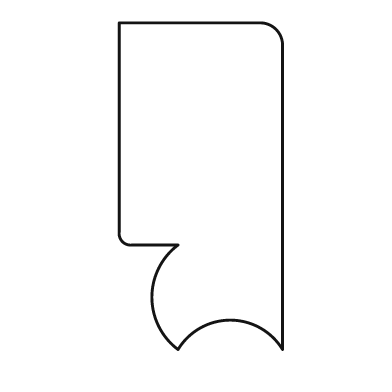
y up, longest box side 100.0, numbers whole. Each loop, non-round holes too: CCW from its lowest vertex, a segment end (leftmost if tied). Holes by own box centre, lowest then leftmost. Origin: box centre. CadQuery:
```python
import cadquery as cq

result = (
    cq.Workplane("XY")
    .moveTo(-7.0, -50.0)
    .threePointArc((9.0, -41.0), (25.0, -50.0))
    .lineTo(25.0, 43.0)
    .threePointArc((23.0, 48.0), (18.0, 50.0))
    .lineTo(-25.0, 50.0)
    .lineTo(-25.0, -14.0)
    .threePointArc((-24.0, -17.0), (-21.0, -18.0))
    .lineTo(-7.0, -18.0)
    .threePointArc((-15.0, -34.0), (-7.0, -50.0))
    .close()
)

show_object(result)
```